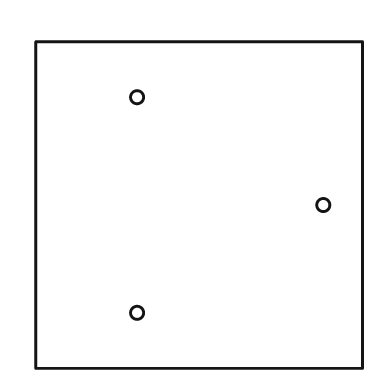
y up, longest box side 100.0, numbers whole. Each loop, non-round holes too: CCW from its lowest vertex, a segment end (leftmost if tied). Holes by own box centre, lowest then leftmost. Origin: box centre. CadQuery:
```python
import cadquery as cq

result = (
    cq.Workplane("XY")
    .moveTo(-50.0, -50.0)
    .lineTo(50.0, -50.0)
    .lineTo(50.0, 50.0)
    .lineTo(-50.0, 50.0)
    .close()
    .moveTo(-19.0, -33.0)
    .circle(2.0)
    .moveTo(38.0, 0.0)
    .circle(2.0)
    .moveTo(-19.0, 33.0)
    .circle(2.0)
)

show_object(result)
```